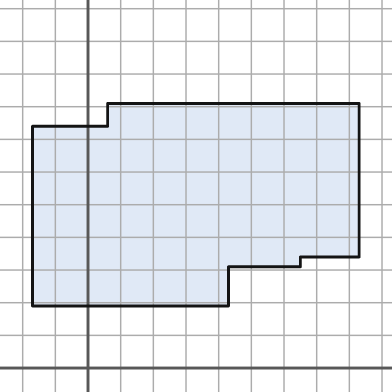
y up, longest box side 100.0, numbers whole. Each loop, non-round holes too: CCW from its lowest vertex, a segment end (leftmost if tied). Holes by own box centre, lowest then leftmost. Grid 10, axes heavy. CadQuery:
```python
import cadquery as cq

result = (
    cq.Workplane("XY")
    .moveTo(-17.0, 19.0)
    .lineTo(43.0, 19.0)
    .lineTo(43.0, 31.0)
    .lineTo(65.0, 31.0)
    .lineTo(65.0, 34.0)
    .lineTo(83.0, 34.0)
    .lineTo(83.0, 81.0)
    .lineTo(6.0, 81.0)
    .lineTo(6.0, 74.0)
    .lineTo(-17.0, 74.0)
    .close()
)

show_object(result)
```